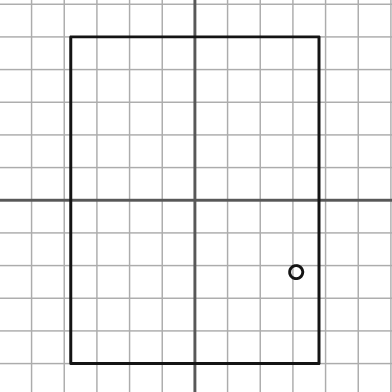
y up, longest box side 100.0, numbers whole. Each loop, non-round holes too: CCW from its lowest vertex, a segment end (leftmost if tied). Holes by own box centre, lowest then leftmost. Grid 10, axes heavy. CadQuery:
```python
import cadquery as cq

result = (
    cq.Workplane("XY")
    .moveTo(-38.0, -50.0)
    .lineTo(38.0, -50.0)
    .lineTo(38.0, 50.0)
    .lineTo(-38.0, 50.0)
    .close()
    .moveTo(31.0, -22.0)
    .circle(2.0)
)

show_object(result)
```